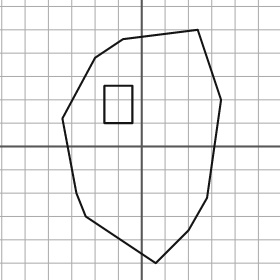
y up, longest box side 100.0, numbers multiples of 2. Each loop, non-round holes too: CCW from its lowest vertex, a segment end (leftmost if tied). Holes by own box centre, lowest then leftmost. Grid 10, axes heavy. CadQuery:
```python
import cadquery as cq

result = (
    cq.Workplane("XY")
    .moveTo(6.0, -50.0)
    .lineTo(20.0, -36.0)
    .lineTo(28.0, -22.0)
    .lineTo(34.0, 20.0)
    .lineTo(24.0, 50.0)
    .lineTo(-8.0, 46.0)
    .lineTo(-20.0, 38.0)
    .lineTo(-34.0, 12.0)
    .lineTo(-28.0, -20.0)
    .lineTo(-24.0, -30.0)
    .close()
    .moveTo(-16.0, 10.0)
    .lineTo(-4.0, 10.0)
    .lineTo(-4.0, 26.0)
    .lineTo(-16.0, 26.0)
    .close()
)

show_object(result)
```